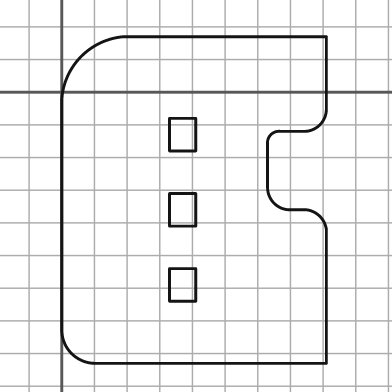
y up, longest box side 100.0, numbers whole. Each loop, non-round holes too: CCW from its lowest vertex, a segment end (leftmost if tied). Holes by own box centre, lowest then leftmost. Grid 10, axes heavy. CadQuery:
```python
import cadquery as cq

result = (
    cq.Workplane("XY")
    .moveTo(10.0, -83.0)
    .lineTo(81.0, -83.0)
    .lineTo(81.0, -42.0)
    .threePointArc((79.0, -38.0), (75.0, -36.0))
    .lineTo(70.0, -36.0)
    .threePointArc((65.0, -34.0), (63.0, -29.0))
    .lineTo(63.0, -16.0)
    .threePointArc((64.0, -13.0), (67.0, -12.0))
    .lineTo(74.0, -12.0)
    .threePointArc((79.0, -10.0), (81.0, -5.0))
    .lineTo(81.0, 17.0)
    .lineTo(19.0, 17.0)
    .threePointArc((6.0, 11.0), (0.0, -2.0))
    .lineTo(0.0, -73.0)
    .threePointArc((3.0, -80.0), (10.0, -83.0))
    .close()
    .moveTo(33.0, -64.0)
    .lineTo(41.0, -64.0)
    .lineTo(41.0, -54.0)
    .lineTo(33.0, -54.0)
    .close()
    .moveTo(33.0, -41.0)
    .lineTo(41.0, -41.0)
    .lineTo(41.0, -31.0)
    .lineTo(33.0, -31.0)
    .close()
    .moveTo(33.0, -18.0)
    .lineTo(41.0, -18.0)
    .lineTo(41.0, -8.0)
    .lineTo(33.0, -8.0)
    .close()
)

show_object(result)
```